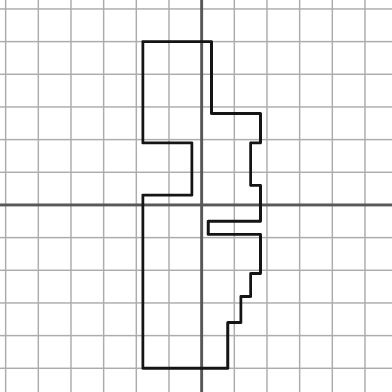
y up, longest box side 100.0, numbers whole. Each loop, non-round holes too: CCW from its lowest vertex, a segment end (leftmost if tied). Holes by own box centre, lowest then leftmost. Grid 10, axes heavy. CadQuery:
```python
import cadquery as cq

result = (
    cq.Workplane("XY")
    .moveTo(-18.0, -50.0)
    .lineTo(8.0, -50.0)
    .lineTo(8.0, -36.0)
    .lineTo(12.0, -36.0)
    .lineTo(12.0, -28.0)
    .lineTo(15.0, -28.0)
    .lineTo(15.0, -21.0)
    .lineTo(18.0, -21.0)
    .lineTo(18.0, -9.0)
    .lineTo(2.0, -9.0)
    .lineTo(2.0, -5.0)
    .lineTo(18.0, -5.0)
    .lineTo(18.0, 6.0)
    .lineTo(15.0, 6.0)
    .lineTo(15.0, 19.0)
    .lineTo(18.0, 19.0)
    .lineTo(18.0, 28.0)
    .lineTo(3.0, 28.0)
    .lineTo(3.0, 50.0)
    .lineTo(-18.0, 50.0)
    .lineTo(-18.0, 19.0)
    .lineTo(-3.0, 19.0)
    .lineTo(-3.0, 3.0)
    .lineTo(-18.0, 3.0)
    .close()
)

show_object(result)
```